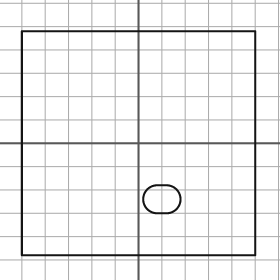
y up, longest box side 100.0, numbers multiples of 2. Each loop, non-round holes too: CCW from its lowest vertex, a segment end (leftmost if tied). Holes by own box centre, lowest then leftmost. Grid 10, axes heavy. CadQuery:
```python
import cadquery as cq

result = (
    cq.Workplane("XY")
    .moveTo(-50.0, -48.0)
    .lineTo(50.0, -48.0)
    .lineTo(50.0, 48.0)
    .lineTo(-50.0, 48.0)
    .close()
    .moveTo(8.0, -30.0)
    .lineTo(12.0, -30.0)
    .threePointArc((18.0, -24.0), (12.0, -18.0))
    .lineTo(8.0, -18.0)
    .threePointArc((2.0, -24.0), (8.0, -30.0))
    .close()
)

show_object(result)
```